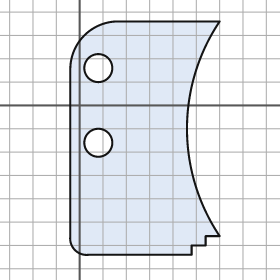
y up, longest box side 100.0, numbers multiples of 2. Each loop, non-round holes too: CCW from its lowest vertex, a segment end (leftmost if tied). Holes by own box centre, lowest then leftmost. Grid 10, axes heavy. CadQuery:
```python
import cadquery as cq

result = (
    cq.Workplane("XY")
    .moveTo(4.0, -64.0)
    .lineTo(48.0, -64.0)
    .lineTo(48.0, -60.0)
    .lineTo(54.0, -60.0)
    .lineTo(54.0, -56.0)
    .lineTo(60.0, -56.0)
    .threePointArc((46.0, -10.0), (60.0, 36.0))
    .lineTo(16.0, 36.0)
    .threePointArc((2.0, 30.0), (-4.0, 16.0))
    .lineTo(-4.0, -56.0)
    .threePointArc((-2.0, -62.0), (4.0, -64.0))
    .close()
    .moveTo(8.0, -16.0)
    .circle(6.0)
    .moveTo(8.0, 16.0)
    .circle(6.0)
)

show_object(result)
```